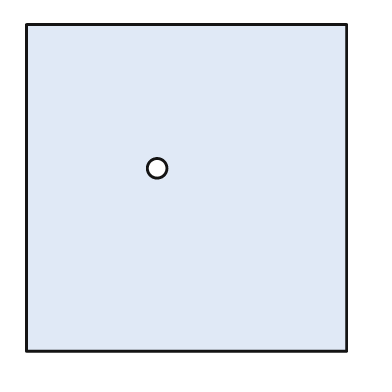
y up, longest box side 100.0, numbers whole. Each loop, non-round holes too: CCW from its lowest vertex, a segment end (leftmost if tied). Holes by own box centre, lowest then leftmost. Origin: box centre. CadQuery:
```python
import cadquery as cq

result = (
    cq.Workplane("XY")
    .moveTo(-49.0, -50.0)
    .lineTo(49.0, -50.0)
    .lineTo(49.0, 50.0)
    .lineTo(-49.0, 50.0)
    .close()
    .moveTo(-9.0, 6.0)
    .circle(3.0)
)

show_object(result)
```